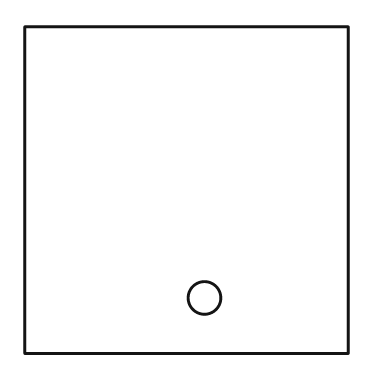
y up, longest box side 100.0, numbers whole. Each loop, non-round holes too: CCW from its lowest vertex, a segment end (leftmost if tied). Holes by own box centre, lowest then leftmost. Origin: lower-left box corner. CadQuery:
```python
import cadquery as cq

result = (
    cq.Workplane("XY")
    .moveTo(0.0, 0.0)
    .lineTo(99.0, 0.0)
    .lineTo(99.0, 100.0)
    .lineTo(0.0, 100.0)
    .close()
    .moveTo(55.0, 17.0)
    .circle(5.0)
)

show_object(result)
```